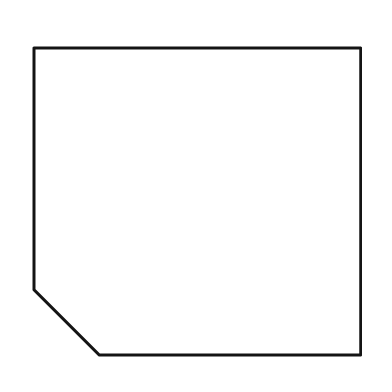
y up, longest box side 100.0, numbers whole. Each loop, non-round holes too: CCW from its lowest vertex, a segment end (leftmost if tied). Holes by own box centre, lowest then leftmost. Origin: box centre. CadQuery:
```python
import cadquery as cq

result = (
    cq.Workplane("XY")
    .moveTo(-30.0, -47.0)
    .lineTo(50.0, -47.0)
    .lineTo(50.0, 47.0)
    .lineTo(-50.0, 47.0)
    .lineTo(-50.0, -27.0)
    .close()
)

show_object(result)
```